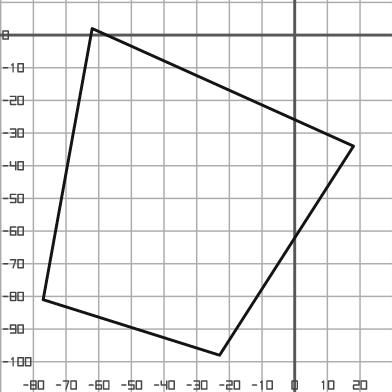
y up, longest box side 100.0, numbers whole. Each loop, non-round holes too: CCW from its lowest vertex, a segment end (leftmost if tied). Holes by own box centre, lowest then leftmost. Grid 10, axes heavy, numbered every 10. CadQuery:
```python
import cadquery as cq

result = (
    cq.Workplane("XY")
    .moveTo(-23.0, -98.0)
    .lineTo(18.0, -34.0)
    .lineTo(-62.0, 2.0)
    .lineTo(-77.0, -81.0)
    .close()
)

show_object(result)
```